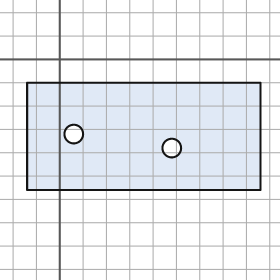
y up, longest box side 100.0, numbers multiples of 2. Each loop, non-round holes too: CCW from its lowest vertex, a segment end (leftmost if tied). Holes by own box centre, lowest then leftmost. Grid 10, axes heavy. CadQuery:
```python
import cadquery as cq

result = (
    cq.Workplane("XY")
    .moveTo(-14.0, -56.0)
    .lineTo(86.0, -56.0)
    .lineTo(86.0, -10.0)
    .lineTo(-14.0, -10.0)
    .close()
    .moveTo(48.0, -38.0)
    .circle(4.0)
    .moveTo(6.0, -32.0)
    .circle(4.0)
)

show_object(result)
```